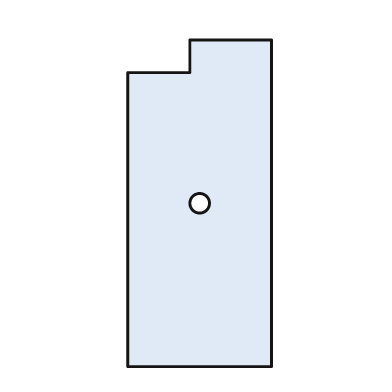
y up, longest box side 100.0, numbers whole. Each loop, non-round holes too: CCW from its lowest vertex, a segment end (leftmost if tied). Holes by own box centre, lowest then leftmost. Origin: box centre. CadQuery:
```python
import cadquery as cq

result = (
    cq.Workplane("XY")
    .moveTo(-22.0, -50.0)
    .lineTo(22.0, -50.0)
    .lineTo(22.0, 50.0)
    .lineTo(-3.0, 50.0)
    .lineTo(-3.0, 40.0)
    .lineTo(-22.0, 40.0)
    .close()
    .moveTo(0.0, 0.0)
    .circle(3.0)
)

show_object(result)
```